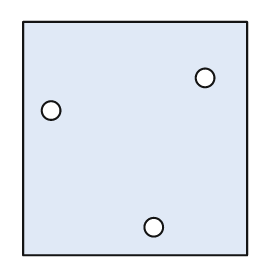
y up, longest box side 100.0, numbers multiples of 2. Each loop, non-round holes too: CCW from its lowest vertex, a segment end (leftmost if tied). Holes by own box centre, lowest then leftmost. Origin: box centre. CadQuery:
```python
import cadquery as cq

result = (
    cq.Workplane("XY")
    .moveTo(-48.0, -50.0)
    .lineTo(48.0, -50.0)
    .lineTo(48.0, 50.0)
    .lineTo(-48.0, 50.0)
    .close()
    .moveTo(8.0, -38.0)
    .circle(4.0)
    .moveTo(-36.0, 12.0)
    .circle(4.0)
    .moveTo(30.0, 26.0)
    .circle(4.0)
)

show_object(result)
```